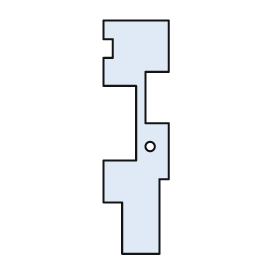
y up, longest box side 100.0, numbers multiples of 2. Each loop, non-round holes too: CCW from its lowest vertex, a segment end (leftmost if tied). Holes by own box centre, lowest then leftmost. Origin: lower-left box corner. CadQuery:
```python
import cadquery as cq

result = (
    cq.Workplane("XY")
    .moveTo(8.0, 0.0)
    .lineTo(24.0, 0.0)
    .lineTo(24.0, 32.0)
    .lineTo(28.0, 32.0)
    .lineTo(28.0, 56.0)
    .lineTo(18.0, 56.0)
    .lineTo(18.0, 78.0)
    .lineTo(28.0, 78.0)
    .lineTo(28.0, 100.0)
    .lineTo(0.0, 100.0)
    .lineTo(0.0, 92.0)
    .lineTo(4.0, 92.0)
    .lineTo(4.0, 84.0)
    .lineTo(0.0, 84.0)
    .lineTo(0.0, 72.0)
    .lineTo(14.0, 72.0)
    .lineTo(14.0, 40.0)
    .lineTo(0.0, 40.0)
    .lineTo(0.0, 22.0)
    .lineTo(8.0, 22.0)
    .close()
    .moveTo(20.0, 46.0)
    .circle(2.0)
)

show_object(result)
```